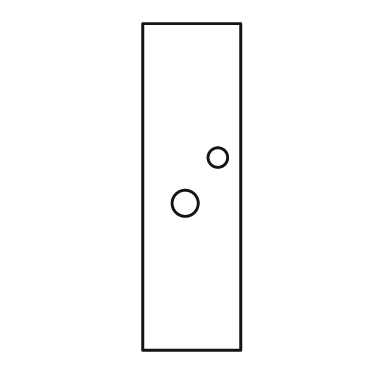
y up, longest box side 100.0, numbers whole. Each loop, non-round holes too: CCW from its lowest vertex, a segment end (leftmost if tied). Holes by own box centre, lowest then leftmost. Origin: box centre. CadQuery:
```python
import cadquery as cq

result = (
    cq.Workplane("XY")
    .moveTo(-15.0, -50.0)
    .lineTo(15.0, -50.0)
    .lineTo(15.0, 50.0)
    .lineTo(-15.0, 50.0)
    .close()
    .moveTo(-2.0, -5.0)
    .circle(4.0)
    .moveTo(8.0, 9.0)
    .circle(3.0)
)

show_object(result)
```